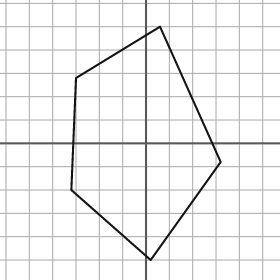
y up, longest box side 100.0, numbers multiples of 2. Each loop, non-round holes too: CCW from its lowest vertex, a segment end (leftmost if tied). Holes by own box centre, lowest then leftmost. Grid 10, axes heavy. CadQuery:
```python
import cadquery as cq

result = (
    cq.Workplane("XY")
    .moveTo(2.0, -50.0)
    .lineTo(32.0, -8.0)
    .lineTo(6.0, 50.0)
    .lineTo(-30.0, 28.0)
    .lineTo(-32.0, -20.0)
    .close()
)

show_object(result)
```